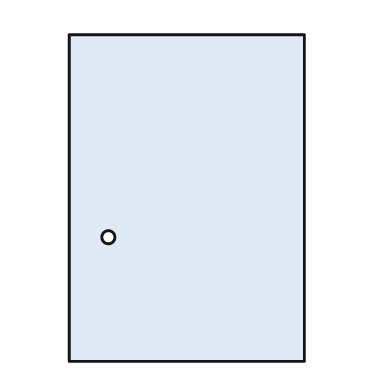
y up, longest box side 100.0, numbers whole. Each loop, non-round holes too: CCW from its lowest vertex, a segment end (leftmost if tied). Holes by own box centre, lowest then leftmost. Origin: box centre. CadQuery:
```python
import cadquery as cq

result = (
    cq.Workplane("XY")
    .moveTo(-36.0, -50.0)
    .lineTo(36.0, -50.0)
    .lineTo(36.0, 50.0)
    .lineTo(-36.0, 50.0)
    .close()
    .moveTo(-24.0, -12.0)
    .circle(2.0)
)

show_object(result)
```